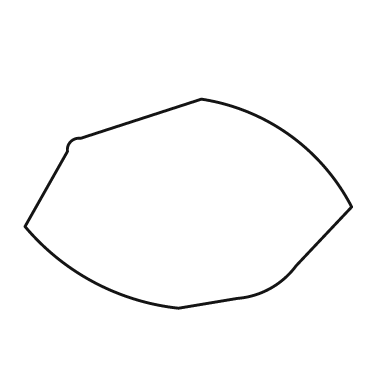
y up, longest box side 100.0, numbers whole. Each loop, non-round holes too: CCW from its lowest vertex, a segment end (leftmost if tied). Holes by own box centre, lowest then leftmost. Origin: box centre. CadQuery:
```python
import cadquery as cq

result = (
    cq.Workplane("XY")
    .moveTo(-3.0, -32.0)
    .lineTo(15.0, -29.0)
    .threePointArc((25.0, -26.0), (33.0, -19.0))
    .lineTo(50.0, -1.0)
    .threePointArc((31.0, 21.0), (4.0, 32.0))
    .lineTo(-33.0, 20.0)
    .threePointArc((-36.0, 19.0), (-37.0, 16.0))
    .lineTo(-50.0, -7.0)
    .threePointArc((-29.0, -24.0), (-3.0, -32.0))
    .close()
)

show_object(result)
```